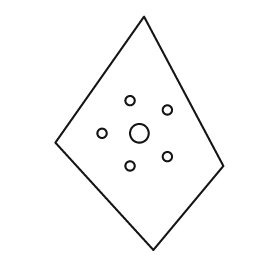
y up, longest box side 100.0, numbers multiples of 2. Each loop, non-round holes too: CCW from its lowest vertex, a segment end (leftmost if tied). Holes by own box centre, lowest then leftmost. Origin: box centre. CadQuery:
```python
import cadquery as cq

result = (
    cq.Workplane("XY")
    .moveTo(6.0, -50.0)
    .lineTo(36.0, -14.0)
    .lineTo(2.0, 50.0)
    .lineTo(-36.0, -4.0)
    .close()
    .moveTo(-4.0, -14.0)
    .circle(2.0)
    .moveTo(12.0, -10.0)
    .circle(2.0)
    .moveTo(-16.0, 0.0)
    .circle(2.0)
    .moveTo(0.0, 0.0)
    .circle(4.0)
    .moveTo(12.0, 10.0)
    .circle(2.0)
    .moveTo(-4.0, 14.0)
    .circle(2.0)
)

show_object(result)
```